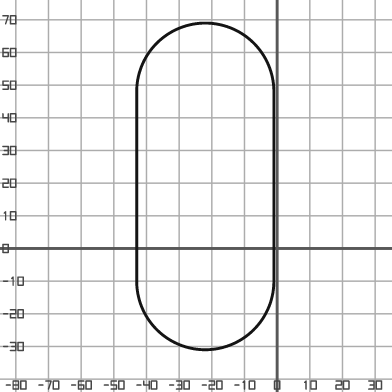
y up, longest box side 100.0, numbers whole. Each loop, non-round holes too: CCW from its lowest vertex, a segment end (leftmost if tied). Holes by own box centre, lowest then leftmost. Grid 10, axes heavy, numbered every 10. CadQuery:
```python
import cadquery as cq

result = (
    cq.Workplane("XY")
    .moveTo(-43.0, -10.0)
    .threePointArc((-22.0, -31.0), (-1.0, -10.0))
    .lineTo(-1.0, 48.0)
    .threePointArc((-22.0, 69.0), (-43.0, 48.0))
    .close()
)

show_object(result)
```